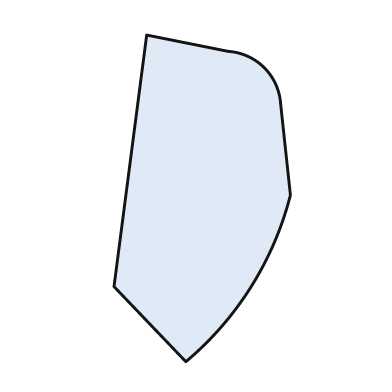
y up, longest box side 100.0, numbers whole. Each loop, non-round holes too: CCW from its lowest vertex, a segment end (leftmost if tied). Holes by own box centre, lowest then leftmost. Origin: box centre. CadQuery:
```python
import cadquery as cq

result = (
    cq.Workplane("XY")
    .moveTo(-5.0, -50.0)
    .threePointArc((15.0, -27.0), (27.0, 1.0))
    .lineTo(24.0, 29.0)
    .threePointArc((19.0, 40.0), (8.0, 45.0))
    .lineTo(-17.0, 50.0)
    .lineTo(-27.0, -27.0)
    .close()
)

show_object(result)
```